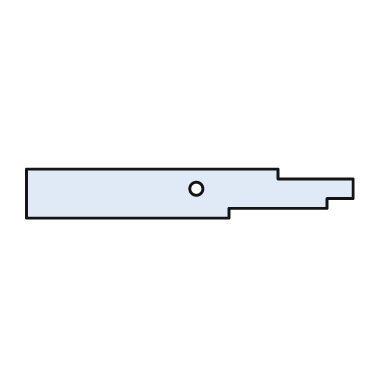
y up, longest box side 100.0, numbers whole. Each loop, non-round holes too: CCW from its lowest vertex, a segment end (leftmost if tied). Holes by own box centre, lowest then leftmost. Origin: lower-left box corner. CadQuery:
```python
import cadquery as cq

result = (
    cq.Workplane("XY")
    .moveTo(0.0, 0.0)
    .lineTo(62.0, 0.0)
    .lineTo(62.0, 3.0)
    .lineTo(92.0, 3.0)
    .lineTo(92.0, 6.0)
    .lineTo(100.0, 6.0)
    .lineTo(100.0, 12.0)
    .lineTo(77.0, 12.0)
    .lineTo(77.0, 15.0)
    .lineTo(0.0, 15.0)
    .close()
    .moveTo(52.0, 9.0)
    .circle(2.0)
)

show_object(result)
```